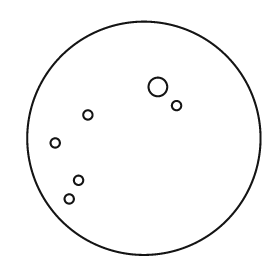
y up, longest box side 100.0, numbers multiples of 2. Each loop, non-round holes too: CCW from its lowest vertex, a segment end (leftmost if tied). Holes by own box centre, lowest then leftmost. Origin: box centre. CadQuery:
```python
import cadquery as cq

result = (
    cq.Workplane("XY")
    .moveTo(0.0, 0.0)
    .circle(50.0)
    .moveTo(-32.0, -26.0)
    .circle(2.0)
    .moveTo(-28.0, -18.0)
    .circle(2.0)
    .moveTo(-38.0, -2.0)
    .circle(2.0)
    .moveTo(-24.0, 10.0)
    .circle(2.0)
    .moveTo(14.0, 14.0)
    .circle(2.0)
    .moveTo(6.0, 22.0)
    .circle(4.0)
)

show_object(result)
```